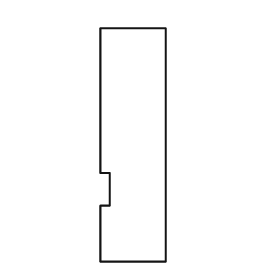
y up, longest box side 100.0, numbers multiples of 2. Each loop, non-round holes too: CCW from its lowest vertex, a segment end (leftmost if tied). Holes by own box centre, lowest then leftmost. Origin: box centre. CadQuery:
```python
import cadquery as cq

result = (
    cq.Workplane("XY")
    .moveTo(-14.0, -50.0)
    .lineTo(14.0, -50.0)
    .lineTo(14.0, 50.0)
    .lineTo(-14.0, 50.0)
    .lineTo(-14.0, -12.0)
    .lineTo(-10.0, -12.0)
    .lineTo(-10.0, -26.0)
    .lineTo(-14.0, -26.0)
    .close()
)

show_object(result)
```